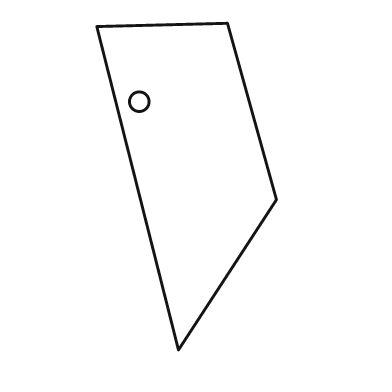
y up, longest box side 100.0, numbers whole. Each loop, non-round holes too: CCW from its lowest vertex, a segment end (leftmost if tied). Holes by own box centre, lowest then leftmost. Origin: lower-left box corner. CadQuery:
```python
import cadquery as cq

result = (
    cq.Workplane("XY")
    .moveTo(25.0, 0.0)
    .lineTo(55.0, 46.0)
    .lineTo(40.0, 100.0)
    .lineTo(0.0, 99.0)
    .close()
    .moveTo(13.0, 76.0)
    .circle(3.0)
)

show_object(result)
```